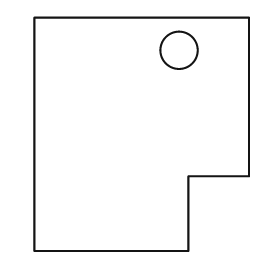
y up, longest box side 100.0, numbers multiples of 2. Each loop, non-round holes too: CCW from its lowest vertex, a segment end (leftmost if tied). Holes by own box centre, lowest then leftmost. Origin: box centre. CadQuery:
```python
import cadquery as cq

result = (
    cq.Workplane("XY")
    .moveTo(-46.0, -50.0)
    .lineTo(20.0, -50.0)
    .lineTo(20.0, -18.0)
    .lineTo(46.0, -18.0)
    .lineTo(46.0, 50.0)
    .lineTo(-46.0, 50.0)
    .close()
    .moveTo(16.0, 36.0)
    .circle(8.0)
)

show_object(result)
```